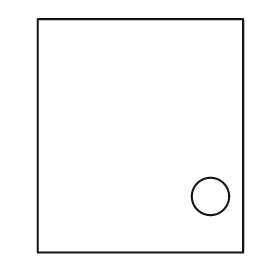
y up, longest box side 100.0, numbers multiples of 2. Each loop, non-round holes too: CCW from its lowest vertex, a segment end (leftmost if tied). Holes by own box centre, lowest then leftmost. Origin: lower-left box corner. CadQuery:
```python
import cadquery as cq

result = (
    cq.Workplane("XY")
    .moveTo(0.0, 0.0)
    .lineTo(88.0, 0.0)
    .lineTo(88.0, 100.0)
    .lineTo(0.0, 100.0)
    .close()
    .moveTo(74.0, 24.0)
    .circle(8.0)
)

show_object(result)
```